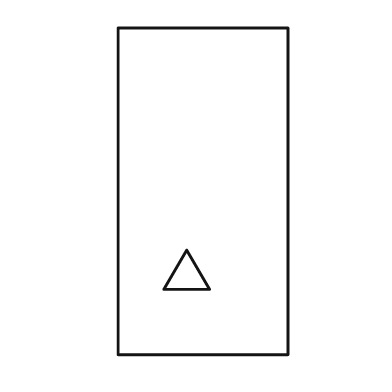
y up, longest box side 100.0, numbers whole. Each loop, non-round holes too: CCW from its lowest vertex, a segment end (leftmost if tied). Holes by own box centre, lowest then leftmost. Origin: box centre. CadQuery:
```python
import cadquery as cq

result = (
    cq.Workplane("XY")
    .moveTo(-26.0, -50.0)
    .lineTo(26.0, -50.0)
    .lineTo(26.0, 50.0)
    .lineTo(-26.0, 50.0)
    .close()
    .moveTo(-12.0, -30.0)
    .lineTo(2.0, -30.0)
    .lineTo(-5.0, -18.0)
    .close()
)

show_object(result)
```